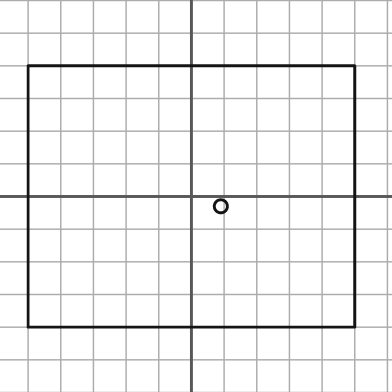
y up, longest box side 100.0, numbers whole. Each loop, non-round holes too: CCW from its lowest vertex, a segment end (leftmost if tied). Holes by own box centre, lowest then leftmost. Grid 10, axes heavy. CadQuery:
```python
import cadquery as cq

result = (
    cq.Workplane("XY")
    .moveTo(-50.0, -40.0)
    .lineTo(50.0, -40.0)
    .lineTo(50.0, 40.0)
    .lineTo(-50.0, 40.0)
    .close()
    .moveTo(9.0, -3.0)
    .circle(2.0)
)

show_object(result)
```